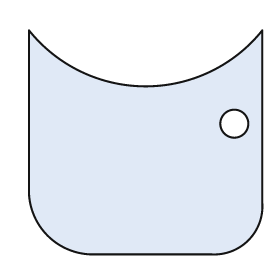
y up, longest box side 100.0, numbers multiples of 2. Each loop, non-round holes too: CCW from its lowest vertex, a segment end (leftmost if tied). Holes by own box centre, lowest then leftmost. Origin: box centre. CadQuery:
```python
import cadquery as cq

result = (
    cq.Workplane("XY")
    .moveTo(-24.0, -48.0)
    .lineTo(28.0, -48.0)
    .threePointArc((44.0, -42.0), (50.0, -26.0))
    .lineTo(50.0, 48.0)
    .threePointArc((0.0, 24.0), (-50.0, 48.0))
    .lineTo(-50.0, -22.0)
    .threePointArc((-42.0, -40.0), (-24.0, -48.0))
    .close()
    .moveTo(38.0, 8.0)
    .circle(6.0)
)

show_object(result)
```